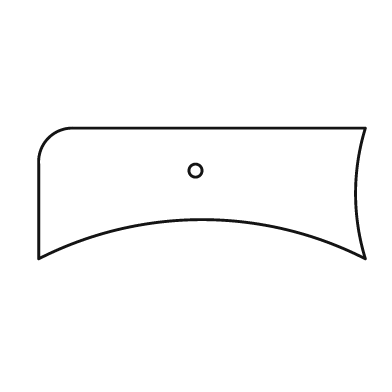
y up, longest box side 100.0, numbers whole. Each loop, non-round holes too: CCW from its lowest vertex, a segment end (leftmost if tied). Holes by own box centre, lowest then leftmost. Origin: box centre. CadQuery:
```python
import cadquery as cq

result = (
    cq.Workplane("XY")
    .moveTo(-50.0, -20.0)
    .threePointArc((0.0, -8.0), (50.0, -20.0))
    .threePointArc((47.0, 0.0), (50.0, 20.0))
    .lineTo(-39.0, 20.0)
    .threePointArc((-47.0, 17.0), (-50.0, 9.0))
    .close()
    .moveTo(-2.0, 7.0)
    .circle(2.0)
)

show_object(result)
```